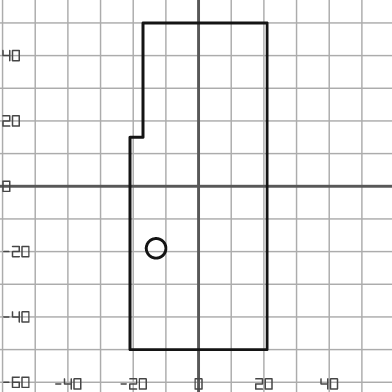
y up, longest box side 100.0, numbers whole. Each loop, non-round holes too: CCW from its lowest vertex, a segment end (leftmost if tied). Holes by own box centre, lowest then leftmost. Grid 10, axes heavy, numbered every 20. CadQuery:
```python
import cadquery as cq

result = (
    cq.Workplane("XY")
    .moveTo(-21.0, -50.0)
    .lineTo(21.0, -50.0)
    .lineTo(21.0, 50.0)
    .lineTo(-17.0, 50.0)
    .lineTo(-17.0, 15.0)
    .lineTo(-21.0, 15.0)
    .close()
    .moveTo(-13.0, -19.0)
    .circle(3.0)
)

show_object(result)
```